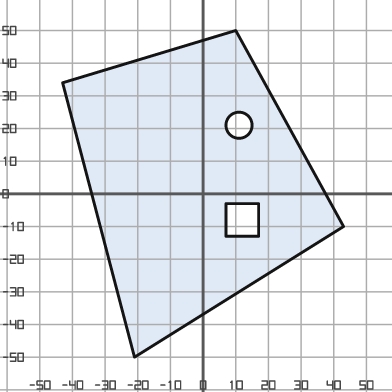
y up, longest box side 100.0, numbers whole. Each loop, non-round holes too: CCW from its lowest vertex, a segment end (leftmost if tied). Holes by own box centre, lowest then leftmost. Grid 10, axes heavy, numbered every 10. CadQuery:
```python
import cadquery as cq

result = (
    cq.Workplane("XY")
    .moveTo(-21.0, -50.0)
    .lineTo(43.0, -10.0)
    .lineTo(10.0, 50.0)
    .lineTo(-43.0, 34.0)
    .close()
    .moveTo(7.0, -13.0)
    .lineTo(17.0, -13.0)
    .lineTo(17.0, -3.0)
    .lineTo(7.0, -3.0)
    .close()
    .moveTo(11.0, 21.0)
    .circle(4.0)
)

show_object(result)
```